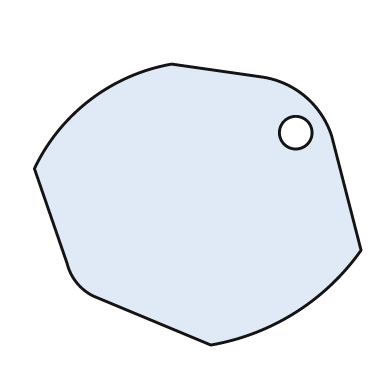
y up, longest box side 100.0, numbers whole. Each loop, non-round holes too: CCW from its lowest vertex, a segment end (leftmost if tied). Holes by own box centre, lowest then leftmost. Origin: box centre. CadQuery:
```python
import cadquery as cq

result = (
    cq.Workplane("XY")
    .moveTo(4.0, -43.0)
    .threePointArc((30.0, -33.0), (50.0, -14.0))
    .lineTo(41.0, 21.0)
    .threePointArc((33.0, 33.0), (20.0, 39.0))
    .lineTo(-8.0, 43.0)
    .threePointArc((-33.0, 32.0), (-50.0, 11.0))
    .lineTo(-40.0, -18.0)
    .threePointArc((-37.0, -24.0), (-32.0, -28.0))
    .close()
    .moveTo(30.0, 22.0)
    .circle(5.0)
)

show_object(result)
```